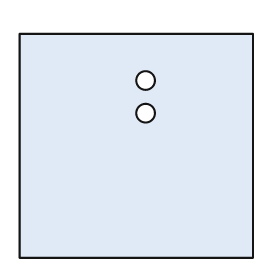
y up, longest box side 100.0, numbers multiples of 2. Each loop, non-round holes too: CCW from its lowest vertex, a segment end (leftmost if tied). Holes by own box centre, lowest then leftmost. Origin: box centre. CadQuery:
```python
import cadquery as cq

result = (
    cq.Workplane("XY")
    .moveTo(-50.0, -48.0)
    .lineTo(50.0, -48.0)
    .lineTo(50.0, 48.0)
    .lineTo(-50.0, 48.0)
    .close()
    .moveTo(4.0, 14.0)
    .circle(4.0)
    .moveTo(4.0, 28.0)
    .circle(4.0)
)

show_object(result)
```